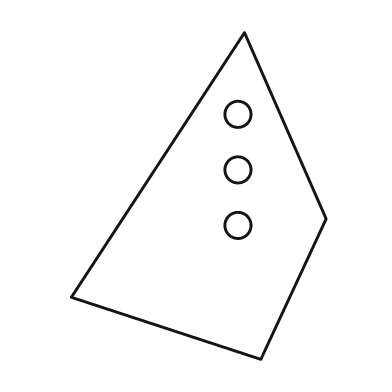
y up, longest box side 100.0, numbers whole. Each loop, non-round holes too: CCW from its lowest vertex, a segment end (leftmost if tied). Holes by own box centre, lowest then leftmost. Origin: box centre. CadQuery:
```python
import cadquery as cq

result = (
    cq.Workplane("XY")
    .moveTo(19.0, -50.0)
    .lineTo(39.0, -7.0)
    .lineTo(14.0, 50.0)
    .lineTo(-39.0, -31.0)
    .close()
    .moveTo(12.0, -9.0)
    .circle(4.0)
    .moveTo(12.0, 8.0)
    .circle(4.0)
    .moveTo(12.0, 25.0)
    .circle(4.0)
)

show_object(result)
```